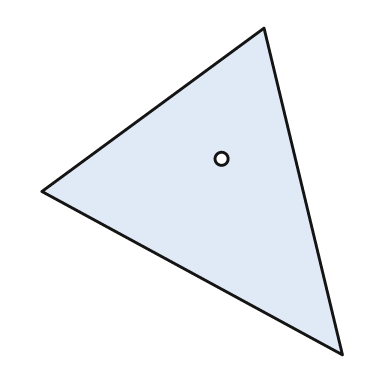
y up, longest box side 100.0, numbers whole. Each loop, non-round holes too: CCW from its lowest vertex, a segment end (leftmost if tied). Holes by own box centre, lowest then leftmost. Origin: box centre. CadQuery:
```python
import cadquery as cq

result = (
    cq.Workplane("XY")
    .moveTo(46.0, -50.0)
    .lineTo(22.0, 50.0)
    .lineTo(-46.0, 0.0)
    .close()
    .moveTo(9.0, 10.0)
    .circle(2.0)
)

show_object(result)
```